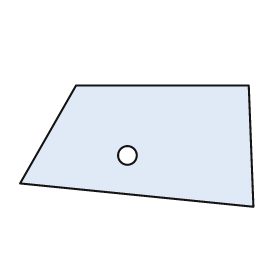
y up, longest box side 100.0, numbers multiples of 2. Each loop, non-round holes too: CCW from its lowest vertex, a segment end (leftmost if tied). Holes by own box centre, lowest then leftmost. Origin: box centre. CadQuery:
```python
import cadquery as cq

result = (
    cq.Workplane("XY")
    .moveTo(50.0, -26.0)
    .lineTo(48.0, 26.0)
    .lineTo(-26.0, 26.0)
    .lineTo(-50.0, -16.0)
    .close()
    .moveTo(-4.0, -4.0)
    .circle(4.0)
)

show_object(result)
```